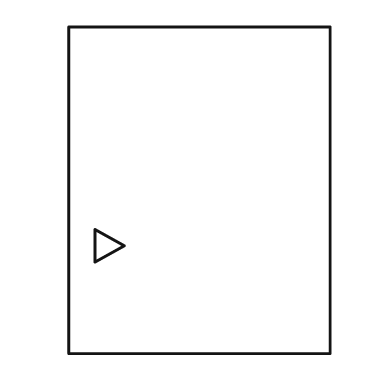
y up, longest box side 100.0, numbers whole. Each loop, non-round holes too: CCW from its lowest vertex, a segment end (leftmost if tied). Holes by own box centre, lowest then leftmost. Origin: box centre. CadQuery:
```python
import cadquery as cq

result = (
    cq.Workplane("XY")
    .moveTo(-40.0, -50.0)
    .lineTo(40.0, -50.0)
    .lineTo(40.0, 50.0)
    .lineTo(-40.0, 50.0)
    .close()
    .moveTo(-32.0, -22.0)
    .lineTo(-23.0, -17.0)
    .lineTo(-32.0, -12.0)
    .close()
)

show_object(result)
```